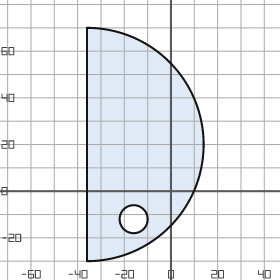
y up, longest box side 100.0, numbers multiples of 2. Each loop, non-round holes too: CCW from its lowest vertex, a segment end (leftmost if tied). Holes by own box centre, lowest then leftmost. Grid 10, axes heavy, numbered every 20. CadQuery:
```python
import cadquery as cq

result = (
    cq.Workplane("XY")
    .moveTo(-36.0, -30.0)
    .threePointArc((14.0, 20.0), (-36.0, 70.0))
    .close()
    .moveTo(-16.0, -12.0)
    .circle(6.0)
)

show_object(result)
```